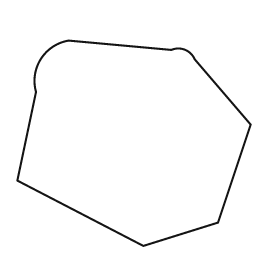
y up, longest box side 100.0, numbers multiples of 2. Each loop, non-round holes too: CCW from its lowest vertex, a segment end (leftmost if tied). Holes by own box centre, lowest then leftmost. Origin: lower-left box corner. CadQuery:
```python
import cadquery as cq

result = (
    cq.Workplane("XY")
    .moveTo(54.0, 0.0)
    .lineTo(86.0, 10.0)
    .lineTo(100.0, 52.0)
    .lineTo(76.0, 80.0)
    .threePointArc((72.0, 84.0), (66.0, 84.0))
    .lineTo(22.0, 88.0)
    .threePointArc((10.0, 80.0), (8.0, 66.0))
    .lineTo(0.0, 28.0)
    .close()
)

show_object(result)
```